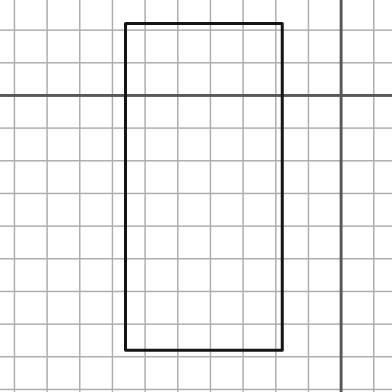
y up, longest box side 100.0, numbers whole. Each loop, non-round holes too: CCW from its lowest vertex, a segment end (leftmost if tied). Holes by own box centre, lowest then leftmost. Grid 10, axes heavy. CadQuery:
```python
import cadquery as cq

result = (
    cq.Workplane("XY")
    .moveTo(-66.0, -78.0)
    .lineTo(-18.0, -78.0)
    .lineTo(-18.0, 22.0)
    .lineTo(-66.0, 22.0)
    .close()
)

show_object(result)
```